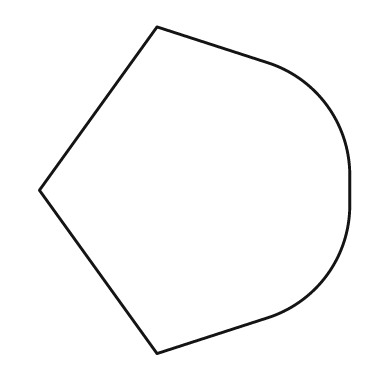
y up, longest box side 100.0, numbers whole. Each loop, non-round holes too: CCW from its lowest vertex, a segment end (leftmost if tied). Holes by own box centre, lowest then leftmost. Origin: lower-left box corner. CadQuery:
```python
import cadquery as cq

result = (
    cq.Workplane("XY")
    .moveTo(36.0, 0.0)
    .lineTo(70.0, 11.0)
    .threePointArc((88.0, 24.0), (95.0, 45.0))
    .lineTo(95.0, 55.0)
    .threePointArc((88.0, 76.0), (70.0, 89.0))
    .lineTo(36.0, 100.0)
    .lineTo(0.0, 50.0)
    .close()
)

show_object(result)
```